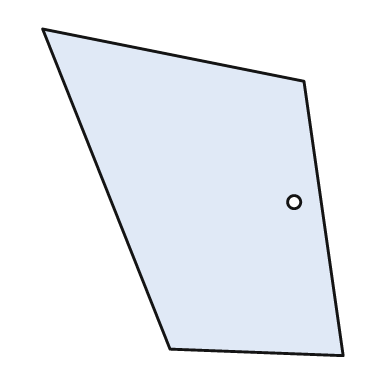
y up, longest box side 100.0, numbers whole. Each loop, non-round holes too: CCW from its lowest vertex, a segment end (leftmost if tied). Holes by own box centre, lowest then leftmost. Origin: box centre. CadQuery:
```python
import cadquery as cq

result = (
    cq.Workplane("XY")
    .moveTo(46.0, -50.0)
    .lineTo(34.0, 34.0)
    .lineTo(-46.0, 50.0)
    .lineTo(-7.0, -48.0)
    .close()
    .moveTo(31.0, -3.0)
    .circle(2.0)
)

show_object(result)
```